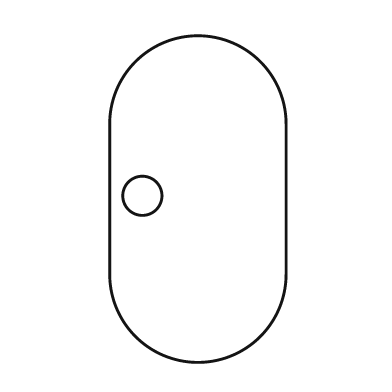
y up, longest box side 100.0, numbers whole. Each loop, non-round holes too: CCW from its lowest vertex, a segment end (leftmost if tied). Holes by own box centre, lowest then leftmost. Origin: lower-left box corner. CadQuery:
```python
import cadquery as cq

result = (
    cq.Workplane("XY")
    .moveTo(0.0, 27.0)
    .threePointArc((27.0, 0.0), (54.0, 27.0))
    .lineTo(54.0, 73.0)
    .threePointArc((27.0, 100.0), (0.0, 73.0))
    .close()
    .moveTo(10.0, 51.0)
    .circle(6.0)
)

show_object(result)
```